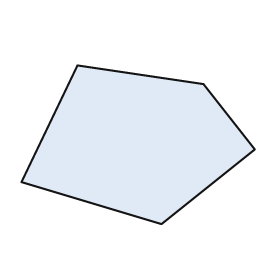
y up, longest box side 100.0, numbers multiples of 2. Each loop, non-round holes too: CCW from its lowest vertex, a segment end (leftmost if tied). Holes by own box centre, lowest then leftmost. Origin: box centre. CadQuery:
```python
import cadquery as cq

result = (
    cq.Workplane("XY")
    .moveTo(10.0, -34.0)
    .lineTo(50.0, -2.0)
    .lineTo(28.0, 26.0)
    .lineTo(-26.0, 34.0)
    .lineTo(-50.0, -16.0)
    .close()
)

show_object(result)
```